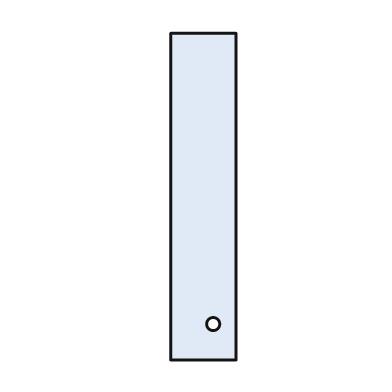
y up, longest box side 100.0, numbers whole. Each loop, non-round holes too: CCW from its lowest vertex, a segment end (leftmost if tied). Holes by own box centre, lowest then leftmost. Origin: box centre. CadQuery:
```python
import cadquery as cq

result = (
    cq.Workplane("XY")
    .moveTo(-10.0, -50.0)
    .lineTo(10.0, -50.0)
    .lineTo(10.0, 50.0)
    .lineTo(-10.0, 50.0)
    .close()
    .moveTo(3.0, -39.0)
    .circle(2.0)
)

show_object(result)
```